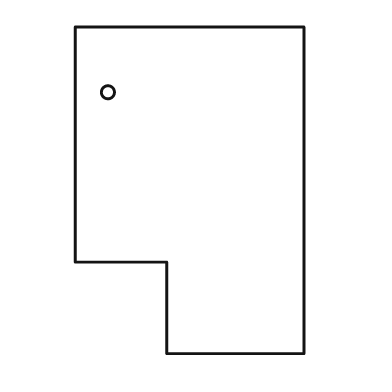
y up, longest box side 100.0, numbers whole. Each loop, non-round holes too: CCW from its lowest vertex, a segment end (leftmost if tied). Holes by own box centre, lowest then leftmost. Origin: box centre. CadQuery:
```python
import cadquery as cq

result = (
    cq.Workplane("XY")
    .moveTo(-7.0, -50.0)
    .lineTo(35.0, -50.0)
    .lineTo(35.0, 50.0)
    .lineTo(-35.0, 50.0)
    .lineTo(-35.0, -22.0)
    .lineTo(-7.0, -22.0)
    .close()
    .moveTo(-25.0, 30.0)
    .circle(2.0)
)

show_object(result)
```